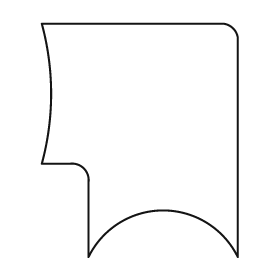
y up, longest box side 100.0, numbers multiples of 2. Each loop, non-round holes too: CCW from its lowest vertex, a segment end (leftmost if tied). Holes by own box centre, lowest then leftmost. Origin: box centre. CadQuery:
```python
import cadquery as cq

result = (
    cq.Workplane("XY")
    .moveTo(-22.0, -50.0)
    .threePointArc((10.0, -30.0), (42.0, -50.0))
    .lineTo(42.0, 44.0)
    .threePointArc((40.0, 48.0), (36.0, 50.0))
    .lineTo(-42.0, 50.0)
    .threePointArc((-38.0, 20.0), (-42.0, -10.0))
    .lineTo(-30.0, -10.0)
    .threePointArc((-24.0, -12.0), (-22.0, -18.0))
    .close()
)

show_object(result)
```